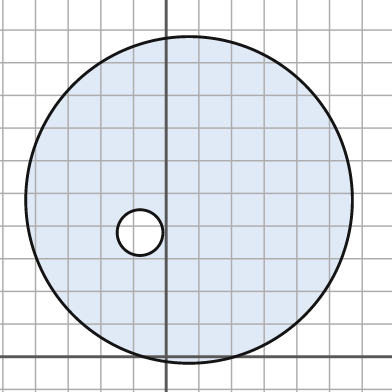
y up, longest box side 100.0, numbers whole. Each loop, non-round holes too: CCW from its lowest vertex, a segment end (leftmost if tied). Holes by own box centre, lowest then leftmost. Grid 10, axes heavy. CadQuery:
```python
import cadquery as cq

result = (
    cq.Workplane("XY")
    .moveTo(7.0, 48.0)
    .circle(50.0)
    .moveTo(-8.0, 38.0)
    .circle(7.0)
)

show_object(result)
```